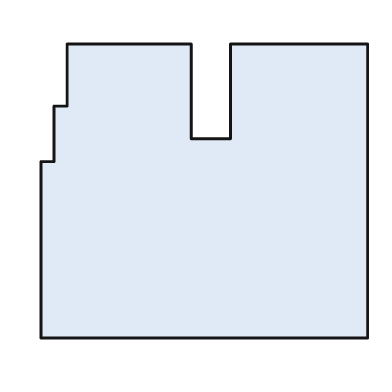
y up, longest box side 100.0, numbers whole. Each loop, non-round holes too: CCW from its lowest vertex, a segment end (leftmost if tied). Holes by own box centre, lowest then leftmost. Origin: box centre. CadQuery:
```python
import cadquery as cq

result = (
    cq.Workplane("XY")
    .moveTo(-50.0, -45.0)
    .lineTo(50.0, -45.0)
    .lineTo(50.0, 45.0)
    .lineTo(8.0, 45.0)
    .lineTo(8.0, 16.0)
    .lineTo(-4.0, 16.0)
    .lineTo(-4.0, 45.0)
    .lineTo(-42.0, 45.0)
    .lineTo(-42.0, 26.0)
    .lineTo(-46.0, 26.0)
    .lineTo(-46.0, 9.0)
    .lineTo(-50.0, 9.0)
    .close()
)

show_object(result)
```